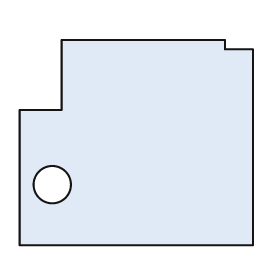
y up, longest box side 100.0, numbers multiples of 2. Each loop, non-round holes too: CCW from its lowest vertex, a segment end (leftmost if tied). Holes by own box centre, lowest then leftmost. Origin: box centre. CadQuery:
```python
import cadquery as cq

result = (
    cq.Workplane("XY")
    .moveTo(-50.0, -44.0)
    .lineTo(50.0, -44.0)
    .lineTo(50.0, 40.0)
    .lineTo(38.0, 40.0)
    .lineTo(38.0, 44.0)
    .lineTo(-32.0, 44.0)
    .lineTo(-32.0, 14.0)
    .lineTo(-50.0, 14.0)
    .close()
    .moveTo(-36.0, -18.0)
    .circle(8.0)
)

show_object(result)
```